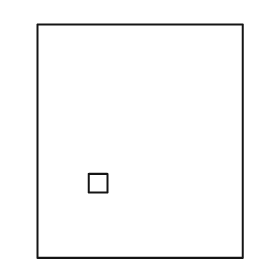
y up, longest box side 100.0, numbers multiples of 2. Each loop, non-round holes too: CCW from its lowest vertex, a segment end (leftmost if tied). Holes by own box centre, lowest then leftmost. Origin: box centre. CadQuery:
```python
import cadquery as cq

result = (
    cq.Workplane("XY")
    .moveTo(-44.0, -50.0)
    .lineTo(44.0, -50.0)
    .lineTo(44.0, 50.0)
    .lineTo(-44.0, 50.0)
    .close()
    .moveTo(-22.0, -22.0)
    .lineTo(-14.0, -22.0)
    .lineTo(-14.0, -14.0)
    .lineTo(-22.0, -14.0)
    .close()
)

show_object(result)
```